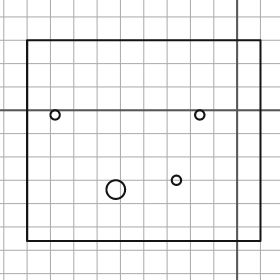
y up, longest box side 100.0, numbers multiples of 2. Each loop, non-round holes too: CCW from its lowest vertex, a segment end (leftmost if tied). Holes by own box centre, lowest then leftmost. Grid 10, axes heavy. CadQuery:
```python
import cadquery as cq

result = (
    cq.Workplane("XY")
    .moveTo(-90.0, -56.0)
    .lineTo(10.0, -56.0)
    .lineTo(10.0, 30.0)
    .lineTo(-90.0, 30.0)
    .close()
    .moveTo(-52.0, -34.0)
    .circle(4.0)
    .moveTo(-26.0, -30.0)
    .circle(2.0)
    .moveTo(-78.0, -2.0)
    .circle(2.0)
    .moveTo(-16.0, -2.0)
    .circle(2.0)
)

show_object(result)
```